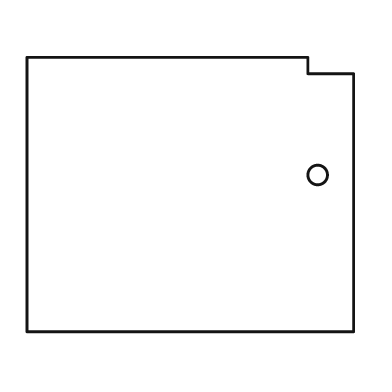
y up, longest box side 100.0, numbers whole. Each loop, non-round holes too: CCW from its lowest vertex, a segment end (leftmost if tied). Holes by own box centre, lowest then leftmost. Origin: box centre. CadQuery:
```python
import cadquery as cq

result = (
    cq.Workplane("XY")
    .moveTo(-50.0, -42.0)
    .lineTo(50.0, -42.0)
    .lineTo(50.0, 37.0)
    .lineTo(36.0, 37.0)
    .lineTo(36.0, 42.0)
    .lineTo(-50.0, 42.0)
    .close()
    .moveTo(39.0, 6.0)
    .circle(3.0)
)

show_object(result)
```